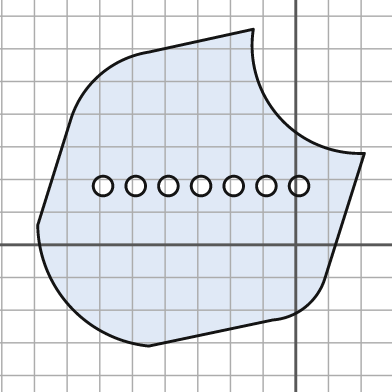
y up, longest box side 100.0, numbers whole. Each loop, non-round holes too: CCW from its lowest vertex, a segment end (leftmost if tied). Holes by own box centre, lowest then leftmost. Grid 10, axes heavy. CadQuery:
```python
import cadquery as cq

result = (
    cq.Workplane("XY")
    .moveTo(-45.0, -31.0)
    .lineTo(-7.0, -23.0)
    .threePointArc((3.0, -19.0), (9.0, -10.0))
    .lineTo(21.0, 28.0)
    .threePointArc((-5.0, 39.0), (-13.0, 66.0))
    .lineTo(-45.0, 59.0)
    .threePointArc((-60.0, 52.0), (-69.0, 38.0))
    .lineTo(-79.0, 6.0)
    .threePointArc((-69.0, -19.0), (-45.0, -31.0))
    .close()
    .moveTo(-59.0, 18.0)
    .circle(3.0)
    .moveTo(-49.0, 18.0)
    .circle(3.0)
    .moveTo(-39.0, 18.0)
    .circle(3.0)
    .moveTo(-29.0, 18.0)
    .circle(3.0)
    .moveTo(-19.0, 18.0)
    .circle(3.0)
    .moveTo(-9.0, 18.0)
    .circle(3.0)
    .moveTo(1.0, 18.0)
    .circle(3.0)
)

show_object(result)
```